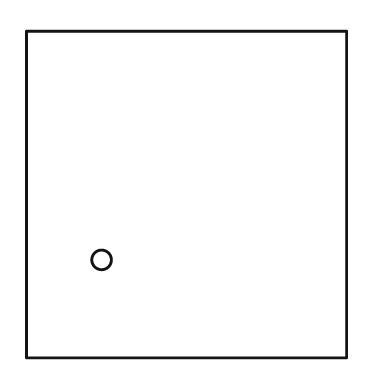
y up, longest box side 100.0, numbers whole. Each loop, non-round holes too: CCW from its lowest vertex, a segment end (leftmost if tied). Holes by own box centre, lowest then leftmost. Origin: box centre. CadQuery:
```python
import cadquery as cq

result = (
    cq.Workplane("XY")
    .moveTo(-49.0, -50.0)
    .lineTo(49.0, -50.0)
    .lineTo(49.0, 50.0)
    .lineTo(-49.0, 50.0)
    .close()
    .moveTo(-26.0, -20.0)
    .circle(3.0)
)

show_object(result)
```